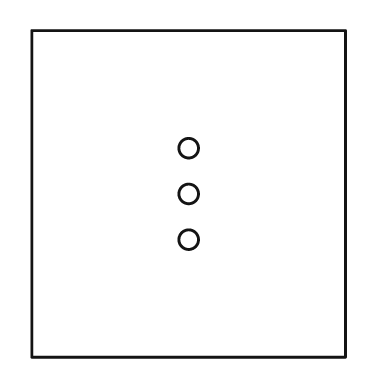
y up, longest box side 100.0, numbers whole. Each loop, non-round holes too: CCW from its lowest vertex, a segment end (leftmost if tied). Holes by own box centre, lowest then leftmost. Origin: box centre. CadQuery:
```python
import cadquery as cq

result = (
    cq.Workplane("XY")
    .moveTo(-48.0, -50.0)
    .lineTo(48.0, -50.0)
    .lineTo(48.0, 50.0)
    .lineTo(-48.0, 50.0)
    .close()
    .moveTo(0.0, -14.0)
    .circle(3.0)
    .moveTo(0.0, 0.0)
    .circle(3.0)
    .moveTo(0.0, 14.0)
    .circle(3.0)
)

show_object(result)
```